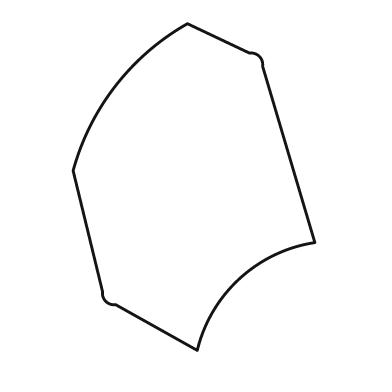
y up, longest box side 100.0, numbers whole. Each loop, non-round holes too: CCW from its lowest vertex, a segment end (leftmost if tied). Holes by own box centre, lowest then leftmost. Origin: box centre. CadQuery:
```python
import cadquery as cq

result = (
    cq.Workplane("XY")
    .moveTo(1.0, -50.0)
    .threePointArc((14.0, -28.0), (37.0, -17.0))
    .lineTo(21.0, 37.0)
    .threePointArc((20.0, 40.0), (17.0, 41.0))
    .lineTo(-2.0, 50.0)
    .threePointArc((-24.0, 31.0), (-37.0, 5.0))
    .lineTo(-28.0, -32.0)
    .threePointArc((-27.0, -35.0), (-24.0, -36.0))
    .close()
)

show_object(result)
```